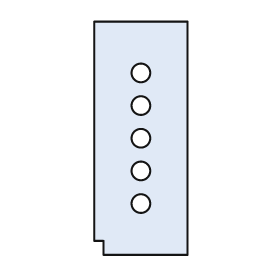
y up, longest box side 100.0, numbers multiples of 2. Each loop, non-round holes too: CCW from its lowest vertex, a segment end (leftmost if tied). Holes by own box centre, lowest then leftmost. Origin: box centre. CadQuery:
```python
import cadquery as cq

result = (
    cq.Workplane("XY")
    .moveTo(-16.0, -50.0)
    .lineTo(20.0, -50.0)
    .lineTo(20.0, 50.0)
    .lineTo(-20.0, 50.0)
    .lineTo(-20.0, -44.0)
    .lineTo(-16.0, -44.0)
    .close()
    .moveTo(0.0, -28.0)
    .circle(4.0)
    .moveTo(0.0, -14.0)
    .circle(4.0)
    .moveTo(0.0, 0.0)
    .circle(4.0)
    .moveTo(0.0, 14.0)
    .circle(4.0)
    .moveTo(0.0, 28.0)
    .circle(4.0)
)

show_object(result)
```